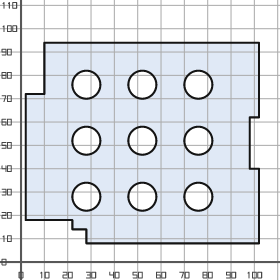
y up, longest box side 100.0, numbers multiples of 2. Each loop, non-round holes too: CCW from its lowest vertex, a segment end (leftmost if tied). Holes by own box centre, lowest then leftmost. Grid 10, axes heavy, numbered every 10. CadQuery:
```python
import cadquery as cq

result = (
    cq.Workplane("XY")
    .moveTo(28.0, 8.0)
    .lineTo(102.0, 8.0)
    .lineTo(102.0, 40.0)
    .lineTo(98.0, 40.0)
    .lineTo(98.0, 62.0)
    .lineTo(102.0, 62.0)
    .lineTo(102.0, 94.0)
    .lineTo(10.0, 94.0)
    .lineTo(10.0, 72.0)
    .lineTo(2.0, 72.0)
    .lineTo(2.0, 18.0)
    .lineTo(22.0, 18.0)
    .lineTo(22.0, 14.0)
    .lineTo(28.0, 14.0)
    .close()
    .moveTo(28.0, 28.0)
    .circle(6.0)
    .moveTo(52.0, 28.0)
    .circle(6.0)
    .moveTo(76.0, 28.0)
    .circle(6.0)
    .moveTo(28.0, 52.0)
    .circle(6.0)
    .moveTo(52.0, 52.0)
    .circle(6.0)
    .moveTo(76.0, 52.0)
    .circle(6.0)
    .moveTo(28.0, 76.0)
    .circle(6.0)
    .moveTo(52.0, 76.0)
    .circle(6.0)
    .moveTo(76.0, 76.0)
    .circle(6.0)
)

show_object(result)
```